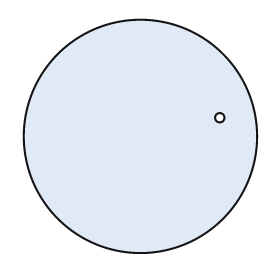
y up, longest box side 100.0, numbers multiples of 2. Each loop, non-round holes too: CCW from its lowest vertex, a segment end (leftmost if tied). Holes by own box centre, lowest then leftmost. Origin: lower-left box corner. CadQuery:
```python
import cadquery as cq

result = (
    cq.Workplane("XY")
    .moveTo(50.0, 50.0)
    .circle(50.0)
    .moveTo(84.0, 58.0)
    .circle(2.0)
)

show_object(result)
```